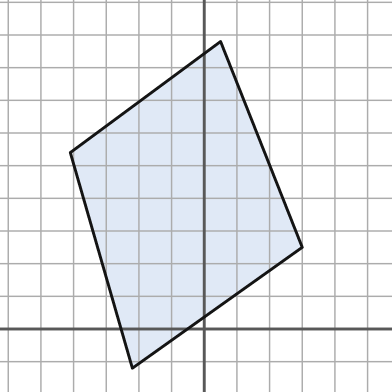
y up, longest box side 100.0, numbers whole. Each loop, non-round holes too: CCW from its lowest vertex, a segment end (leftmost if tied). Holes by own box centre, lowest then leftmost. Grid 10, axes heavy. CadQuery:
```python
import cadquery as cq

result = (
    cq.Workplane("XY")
    .moveTo(-22.0, -12.0)
    .lineTo(30.0, 25.0)
    .lineTo(5.0, 88.0)
    .lineTo(-41.0, 54.0)
    .close()
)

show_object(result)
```